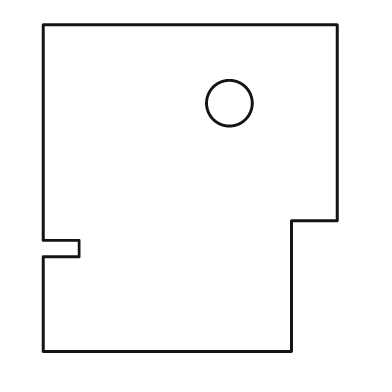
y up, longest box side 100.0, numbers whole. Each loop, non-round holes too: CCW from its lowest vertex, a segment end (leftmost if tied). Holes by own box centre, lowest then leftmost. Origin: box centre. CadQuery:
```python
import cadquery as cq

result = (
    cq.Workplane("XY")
    .moveTo(-45.0, -50.0)
    .lineTo(31.0, -50.0)
    .lineTo(31.0, -10.0)
    .lineTo(45.0, -10.0)
    .lineTo(45.0, 50.0)
    .lineTo(-45.0, 50.0)
    .lineTo(-45.0, -16.0)
    .lineTo(-34.0, -16.0)
    .lineTo(-34.0, -21.0)
    .lineTo(-45.0, -21.0)
    .close()
    .moveTo(12.0, 26.0)
    .circle(7.0)
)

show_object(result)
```